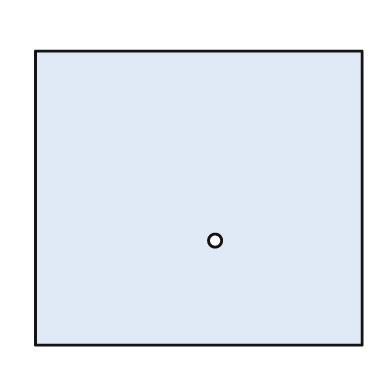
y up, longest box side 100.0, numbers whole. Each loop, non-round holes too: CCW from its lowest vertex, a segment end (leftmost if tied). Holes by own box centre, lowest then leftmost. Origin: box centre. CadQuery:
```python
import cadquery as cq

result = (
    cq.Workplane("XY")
    .moveTo(-50.0, -45.0)
    .lineTo(50.0, -45.0)
    .lineTo(50.0, 45.0)
    .lineTo(-50.0, 45.0)
    .close()
    .moveTo(5.0, -13.0)
    .circle(2.0)
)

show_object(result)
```